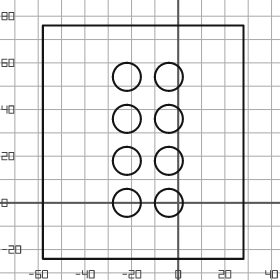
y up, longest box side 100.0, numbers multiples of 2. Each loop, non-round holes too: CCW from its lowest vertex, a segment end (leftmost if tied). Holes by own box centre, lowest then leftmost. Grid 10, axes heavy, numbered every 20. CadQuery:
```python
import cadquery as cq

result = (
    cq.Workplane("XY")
    .moveTo(-58.0, -24.0)
    .lineTo(28.0, -24.0)
    .lineTo(28.0, 76.0)
    .lineTo(-58.0, 76.0)
    .close()
    .moveTo(-22.0, 0.0)
    .circle(6.0)
    .moveTo(-4.0, 0.0)
    .circle(6.0)
    .moveTo(-22.0, 18.0)
    .circle(6.0)
    .moveTo(-4.0, 18.0)
    .circle(6.0)
    .moveTo(-22.0, 36.0)
    .circle(6.0)
    .moveTo(-4.0, 36.0)
    .circle(6.0)
    .moveTo(-22.0, 54.0)
    .circle(6.0)
    .moveTo(-4.0, 54.0)
    .circle(6.0)
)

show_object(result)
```